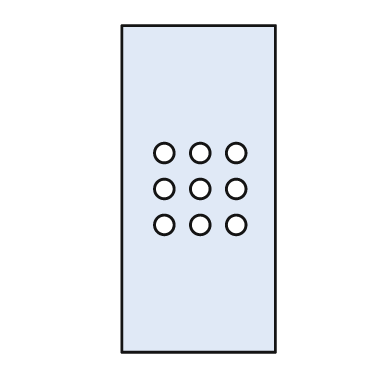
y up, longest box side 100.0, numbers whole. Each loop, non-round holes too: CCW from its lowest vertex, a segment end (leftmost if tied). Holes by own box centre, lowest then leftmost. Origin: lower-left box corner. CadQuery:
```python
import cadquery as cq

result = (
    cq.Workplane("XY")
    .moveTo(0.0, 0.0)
    .lineTo(47.0, 0.0)
    .lineTo(47.0, 100.0)
    .lineTo(0.0, 100.0)
    .close()
    .moveTo(13.0, 39.0)
    .circle(3.0)
    .moveTo(24.0, 39.0)
    .circle(3.0)
    .moveTo(35.0, 39.0)
    .circle(3.0)
    .moveTo(13.0, 50.0)
    .circle(3.0)
    .moveTo(24.0, 50.0)
    .circle(3.0)
    .moveTo(35.0, 50.0)
    .circle(3.0)
    .moveTo(13.0, 61.0)
    .circle(3.0)
    .moveTo(24.0, 61.0)
    .circle(3.0)
    .moveTo(35.0, 61.0)
    .circle(3.0)
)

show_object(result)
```